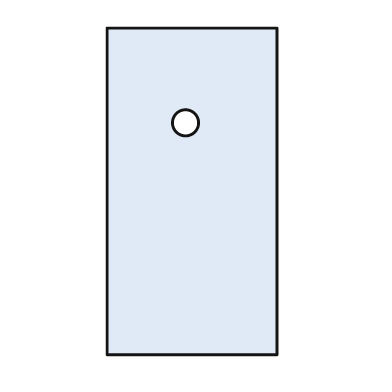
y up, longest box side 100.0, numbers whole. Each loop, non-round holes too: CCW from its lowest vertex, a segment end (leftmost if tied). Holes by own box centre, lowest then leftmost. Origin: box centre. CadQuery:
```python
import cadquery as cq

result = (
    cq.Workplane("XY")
    .moveTo(-26.0, -50.0)
    .lineTo(26.0, -50.0)
    .lineTo(26.0, 50.0)
    .lineTo(-26.0, 50.0)
    .close()
    .moveTo(-2.0, 21.0)
    .circle(4.0)
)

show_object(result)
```